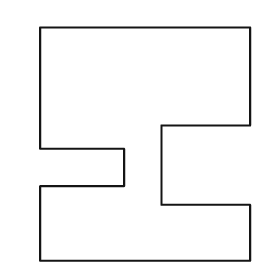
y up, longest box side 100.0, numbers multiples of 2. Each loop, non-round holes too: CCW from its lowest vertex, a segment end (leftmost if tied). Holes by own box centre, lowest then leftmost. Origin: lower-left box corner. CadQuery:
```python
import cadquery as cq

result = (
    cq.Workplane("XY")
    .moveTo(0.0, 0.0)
    .lineTo(90.0, 0.0)
    .lineTo(90.0, 24.0)
    .lineTo(52.0, 24.0)
    .lineTo(52.0, 58.0)
    .lineTo(90.0, 58.0)
    .lineTo(90.0, 100.0)
    .lineTo(0.0, 100.0)
    .lineTo(0.0, 48.0)
    .lineTo(36.0, 48.0)
    .lineTo(36.0, 32.0)
    .lineTo(0.0, 32.0)
    .close()
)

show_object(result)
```